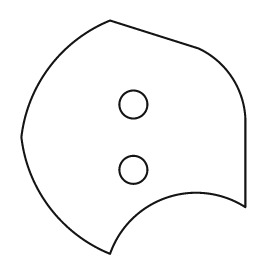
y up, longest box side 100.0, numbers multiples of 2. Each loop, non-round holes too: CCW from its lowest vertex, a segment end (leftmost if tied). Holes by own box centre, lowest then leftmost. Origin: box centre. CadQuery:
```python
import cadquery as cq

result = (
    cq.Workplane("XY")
    .moveTo(-10.0, -50.0)
    .threePointArc((14.0, -26.0), (48.0, -30.0))
    .lineTo(48.0, 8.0)
    .threePointArc((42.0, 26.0), (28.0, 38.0))
    .lineTo(-10.0, 50.0)
    .threePointArc((-36.0, 30.0), (-48.0, 0.0))
    .threePointArc((-36.0, -30.0), (-10.0, -50.0))
    .close()
    .moveTo(0.0, -14.0)
    .circle(6.0)
    .moveTo(0.0, 14.0)
    .circle(6.0)
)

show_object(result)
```